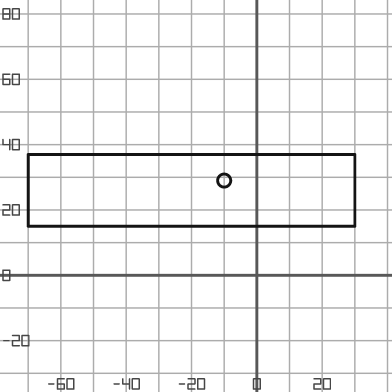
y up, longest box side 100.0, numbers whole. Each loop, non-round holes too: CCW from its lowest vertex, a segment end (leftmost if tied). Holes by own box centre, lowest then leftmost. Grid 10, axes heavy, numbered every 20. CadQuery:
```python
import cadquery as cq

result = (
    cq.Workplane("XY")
    .moveTo(-70.0, 15.0)
    .lineTo(30.0, 15.0)
    .lineTo(30.0, 37.0)
    .lineTo(-70.0, 37.0)
    .close()
    .moveTo(-10.0, 29.0)
    .circle(2.0)
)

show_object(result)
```